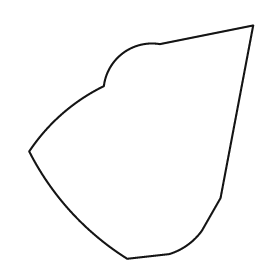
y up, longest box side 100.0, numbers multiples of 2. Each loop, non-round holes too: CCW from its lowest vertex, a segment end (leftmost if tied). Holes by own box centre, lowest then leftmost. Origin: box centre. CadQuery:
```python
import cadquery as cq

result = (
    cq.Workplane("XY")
    .moveTo(-6.0, -50.0)
    .lineTo(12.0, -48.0)
    .threePointArc((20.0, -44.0), (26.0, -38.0))
    .lineTo(34.0, -24.0)
    .lineTo(48.0, 50.0)
    .lineTo(8.0, 42.0)
    .threePointArc((-8.0, 38.0), (-16.0, 24.0))
    .threePointArc((-34.0, 12.0), (-48.0, -4.0))
    .threePointArc((-30.0, -30.0), (-6.0, -50.0))
    .close()
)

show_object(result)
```